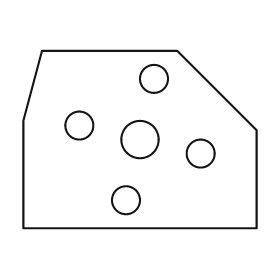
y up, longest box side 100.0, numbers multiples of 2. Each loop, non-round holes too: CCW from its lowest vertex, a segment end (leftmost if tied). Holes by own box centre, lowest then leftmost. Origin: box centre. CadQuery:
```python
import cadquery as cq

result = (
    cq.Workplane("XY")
    .moveTo(-50.0, -38.0)
    .lineTo(50.0, -38.0)
    .lineTo(50.0, 4.0)
    .lineTo(16.0, 38.0)
    .lineTo(-42.0, 38.0)
    .lineTo(-50.0, 8.0)
    .close()
    .moveTo(-6.0, -26.0)
    .circle(6.0)
    .moveTo(26.0, -6.0)
    .circle(6.0)
    .moveTo(0.0, 0.0)
    .circle(8.0)
    .moveTo(-26.0, 6.0)
    .circle(6.0)
    .moveTo(6.0, 26.0)
    .circle(6.0)
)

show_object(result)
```